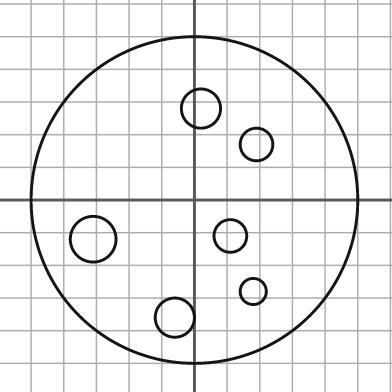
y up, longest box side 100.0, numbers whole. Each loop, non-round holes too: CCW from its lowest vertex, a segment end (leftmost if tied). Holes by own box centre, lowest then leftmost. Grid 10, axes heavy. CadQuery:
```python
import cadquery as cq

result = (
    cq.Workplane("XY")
    .moveTo(0.0, 0.0)
    .circle(50.0)
    .moveTo(-6.0, -36.0)
    .circle(6.0)
    .moveTo(18.0, -28.0)
    .circle(4.0)
    .moveTo(-31.0, -12.0)
    .circle(7.0)
    .moveTo(11.0, -11.0)
    .circle(5.0)
    .moveTo(19.0, 17.0)
    .circle(5.0)
    .moveTo(2.0, 28.0)
    .circle(6.0)
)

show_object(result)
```